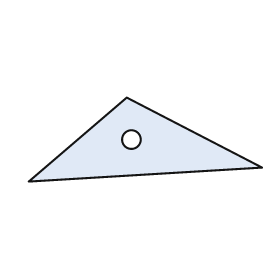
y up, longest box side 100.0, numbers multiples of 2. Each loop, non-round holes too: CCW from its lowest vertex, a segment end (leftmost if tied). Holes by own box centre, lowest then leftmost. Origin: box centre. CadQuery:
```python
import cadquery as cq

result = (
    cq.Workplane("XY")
    .moveTo(-50.0, -18.0)
    .lineTo(50.0, -12.0)
    .lineTo(-8.0, 18.0)
    .close()
    .moveTo(-6.0, 0.0)
    .circle(4.0)
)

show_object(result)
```